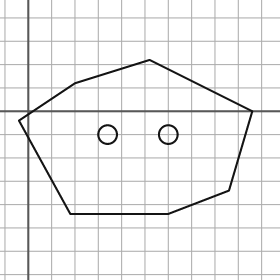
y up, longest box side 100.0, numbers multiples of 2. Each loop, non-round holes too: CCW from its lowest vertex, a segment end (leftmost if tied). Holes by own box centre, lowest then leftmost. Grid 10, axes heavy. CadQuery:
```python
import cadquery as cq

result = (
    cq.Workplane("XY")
    .moveTo(18.0, -44.0)
    .lineTo(60.0, -44.0)
    .lineTo(86.0, -34.0)
    .lineTo(96.0, 0.0)
    .lineTo(52.0, 22.0)
    .lineTo(20.0, 12.0)
    .lineTo(-4.0, -4.0)
    .close()
    .moveTo(34.0, -10.0)
    .circle(4.0)
    .moveTo(60.0, -10.0)
    .circle(4.0)
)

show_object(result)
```